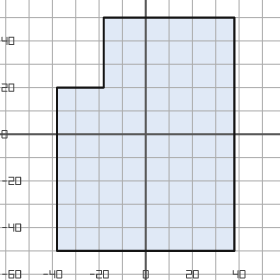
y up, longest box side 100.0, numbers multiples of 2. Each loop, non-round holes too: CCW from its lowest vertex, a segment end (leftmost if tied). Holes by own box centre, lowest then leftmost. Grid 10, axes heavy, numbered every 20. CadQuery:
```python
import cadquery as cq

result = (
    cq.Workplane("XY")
    .moveTo(-38.0, -50.0)
    .lineTo(38.0, -50.0)
    .lineTo(38.0, 50.0)
    .lineTo(-18.0, 50.0)
    .lineTo(-18.0, 20.0)
    .lineTo(-38.0, 20.0)
    .close()
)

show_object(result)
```